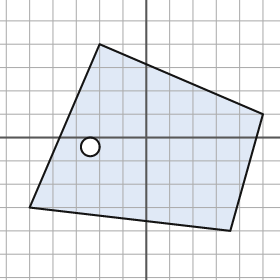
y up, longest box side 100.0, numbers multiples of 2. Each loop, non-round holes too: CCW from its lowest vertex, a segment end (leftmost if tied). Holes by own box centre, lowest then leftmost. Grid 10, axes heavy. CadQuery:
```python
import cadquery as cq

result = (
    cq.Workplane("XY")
    .moveTo(36.0, -40.0)
    .lineTo(50.0, 10.0)
    .lineTo(-20.0, 40.0)
    .lineTo(-50.0, -30.0)
    .close()
    .moveTo(-24.0, -4.0)
    .circle(4.0)
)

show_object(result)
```